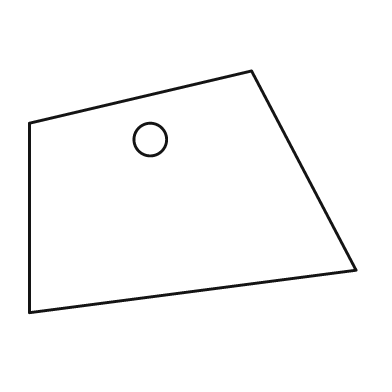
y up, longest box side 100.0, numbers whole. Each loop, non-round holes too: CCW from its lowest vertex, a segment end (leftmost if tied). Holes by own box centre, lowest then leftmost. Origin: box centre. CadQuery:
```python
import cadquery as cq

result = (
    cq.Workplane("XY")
    .moveTo(-50.0, -37.0)
    .lineTo(50.0, -24.0)
    .lineTo(18.0, 37.0)
    .lineTo(-50.0, 21.0)
    .close()
    .moveTo(-13.0, 16.0)
    .circle(5.0)
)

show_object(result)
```